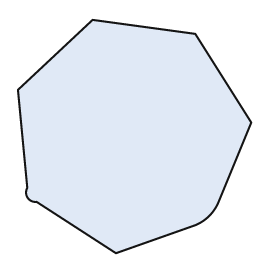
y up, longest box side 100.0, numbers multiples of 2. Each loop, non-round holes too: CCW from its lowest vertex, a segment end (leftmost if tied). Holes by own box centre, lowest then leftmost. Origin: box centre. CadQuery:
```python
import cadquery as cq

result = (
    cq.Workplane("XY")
    .moveTo(-8.0, -50.0)
    .lineTo(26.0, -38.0)
    .threePointArc((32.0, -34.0), (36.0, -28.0))
    .lineTo(50.0, 6.0)
    .lineTo(26.0, 44.0)
    .lineTo(-18.0, 50.0)
    .lineTo(-50.0, 20.0)
    .lineTo(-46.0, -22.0)
    .threePointArc((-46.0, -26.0), (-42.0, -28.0))
    .close()
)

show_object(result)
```